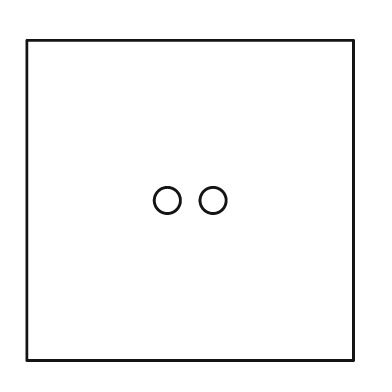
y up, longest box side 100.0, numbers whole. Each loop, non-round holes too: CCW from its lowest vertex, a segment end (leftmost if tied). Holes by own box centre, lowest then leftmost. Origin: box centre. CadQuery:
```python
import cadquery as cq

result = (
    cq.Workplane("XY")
    .moveTo(-50.0, -49.0)
    .lineTo(50.0, -49.0)
    .lineTo(50.0, 49.0)
    .lineTo(-50.0, 49.0)
    .close()
    .moveTo(-7.0, 0.0)
    .circle(4.0)
    .moveTo(7.0, 0.0)
    .circle(4.0)
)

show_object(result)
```